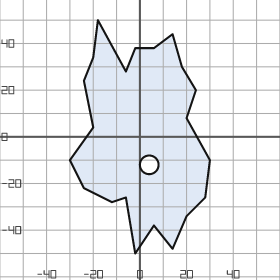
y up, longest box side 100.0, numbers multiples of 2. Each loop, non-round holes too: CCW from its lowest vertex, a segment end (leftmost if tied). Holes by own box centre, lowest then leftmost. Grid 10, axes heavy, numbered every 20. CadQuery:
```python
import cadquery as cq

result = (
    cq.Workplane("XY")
    .moveTo(-2.0, -50.0)
    .lineTo(6.0, -38.0)
    .lineTo(14.0, -48.0)
    .lineTo(20.0, -34.0)
    .lineTo(28.0, -26.0)
    .lineTo(30.0, -10.0)
    .lineTo(20.0, 8.0)
    .lineTo(24.0, 20.0)
    .lineTo(18.0, 30.0)
    .lineTo(14.0, 44.0)
    .lineTo(6.0, 38.0)
    .lineTo(-2.0, 38.0)
    .lineTo(-6.0, 28.0)
    .lineTo(-18.0, 50.0)
    .lineTo(-20.0, 34.0)
    .lineTo(-24.0, 24.0)
    .lineTo(-20.0, 4.0)
    .lineTo(-30.0, -10.0)
    .lineTo(-24.0, -22.0)
    .lineTo(-12.0, -28.0)
    .lineTo(-6.0, -26.0)
    .close()
    .moveTo(4.0, -12.0)
    .circle(4.0)
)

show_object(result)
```